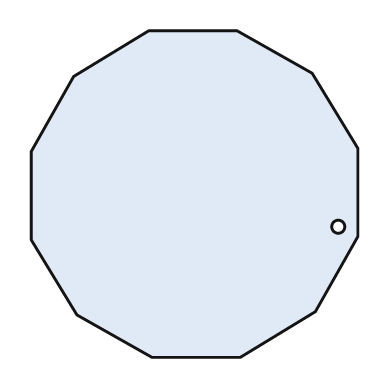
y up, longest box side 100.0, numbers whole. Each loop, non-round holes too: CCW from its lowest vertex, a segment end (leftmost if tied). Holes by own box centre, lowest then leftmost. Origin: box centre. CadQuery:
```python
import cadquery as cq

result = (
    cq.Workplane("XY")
    .moveTo(-13.0, -50.0)
    .lineTo(14.0, -50.0)
    .lineTo(37.0, -36.0)
    .lineTo(50.0, -13.0)
    .lineTo(50.0, 14.0)
    .lineTo(36.0, 37.0)
    .lineTo(13.0, 50.0)
    .lineTo(-14.0, 50.0)
    .lineTo(-37.0, 36.0)
    .lineTo(-50.0, 13.0)
    .lineTo(-50.0, -14.0)
    .lineTo(-36.0, -37.0)
    .close()
    .moveTo(44.0, -10.0)
    .circle(2.0)
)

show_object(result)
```